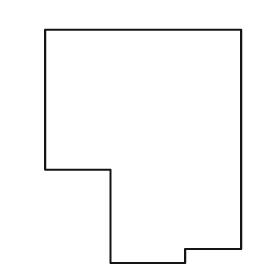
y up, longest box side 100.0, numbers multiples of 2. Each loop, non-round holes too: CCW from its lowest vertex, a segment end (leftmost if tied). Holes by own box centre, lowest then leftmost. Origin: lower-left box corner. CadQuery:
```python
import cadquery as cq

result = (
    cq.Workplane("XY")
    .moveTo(28.0, 0.0)
    .lineTo(60.0, 0.0)
    .lineTo(60.0, 6.0)
    .lineTo(84.0, 6.0)
    .lineTo(84.0, 100.0)
    .lineTo(0.0, 100.0)
    .lineTo(0.0, 40.0)
    .lineTo(28.0, 40.0)
    .close()
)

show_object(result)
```